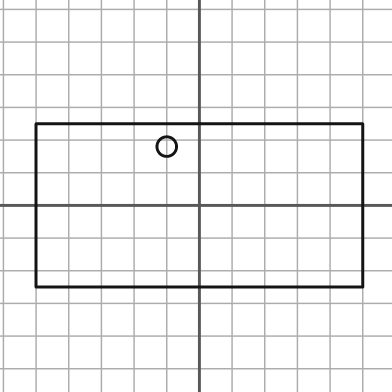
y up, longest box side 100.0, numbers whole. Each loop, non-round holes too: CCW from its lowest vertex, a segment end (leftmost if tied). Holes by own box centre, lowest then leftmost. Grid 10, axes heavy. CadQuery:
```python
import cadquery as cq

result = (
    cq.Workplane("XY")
    .moveTo(-50.0, -25.0)
    .lineTo(50.0, -25.0)
    .lineTo(50.0, 25.0)
    .lineTo(-50.0, 25.0)
    .close()
    .moveTo(-10.0, 18.0)
    .circle(3.0)
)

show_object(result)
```